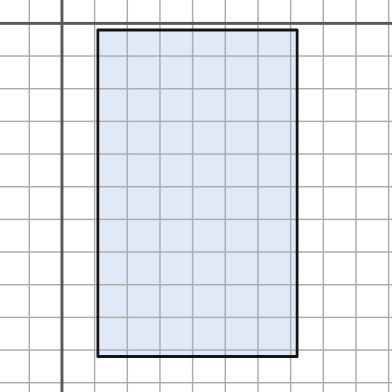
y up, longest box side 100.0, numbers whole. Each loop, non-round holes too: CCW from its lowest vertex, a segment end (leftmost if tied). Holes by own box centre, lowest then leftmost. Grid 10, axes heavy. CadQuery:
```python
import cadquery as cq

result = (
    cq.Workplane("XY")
    .moveTo(11.0, -102.0)
    .lineTo(72.0, -102.0)
    .lineTo(72.0, -2.0)
    .lineTo(11.0, -2.0)
    .close()
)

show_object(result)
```